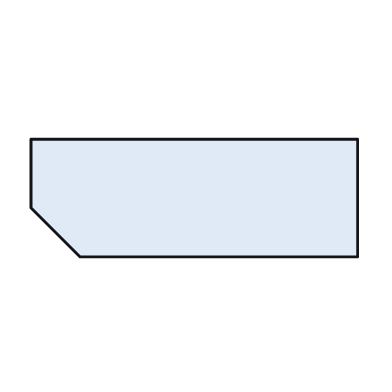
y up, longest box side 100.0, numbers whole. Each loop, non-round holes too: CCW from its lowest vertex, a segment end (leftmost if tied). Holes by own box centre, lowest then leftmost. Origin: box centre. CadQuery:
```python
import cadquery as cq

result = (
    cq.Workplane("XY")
    .moveTo(-35.0, -18.0)
    .lineTo(50.0, -18.0)
    .lineTo(50.0, 18.0)
    .lineTo(-50.0, 18.0)
    .lineTo(-50.0, -3.0)
    .close()
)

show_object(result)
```